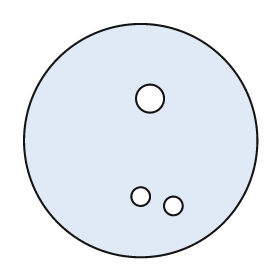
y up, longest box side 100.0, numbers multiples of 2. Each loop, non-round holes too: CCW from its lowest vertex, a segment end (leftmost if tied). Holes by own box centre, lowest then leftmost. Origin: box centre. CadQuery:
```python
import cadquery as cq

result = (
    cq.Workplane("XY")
    .moveTo(0.0, 0.0)
    .circle(50.0)
    .moveTo(14.0, -28.0)
    .circle(4.0)
    .moveTo(0.0, -24.0)
    .circle(4.0)
    .moveTo(4.0, 18.0)
    .circle(6.0)
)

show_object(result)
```